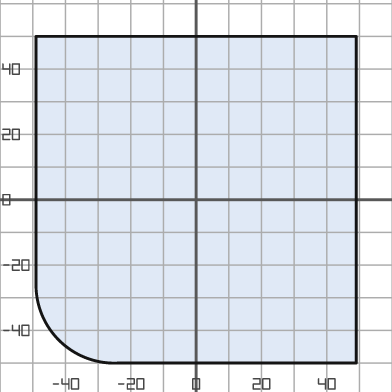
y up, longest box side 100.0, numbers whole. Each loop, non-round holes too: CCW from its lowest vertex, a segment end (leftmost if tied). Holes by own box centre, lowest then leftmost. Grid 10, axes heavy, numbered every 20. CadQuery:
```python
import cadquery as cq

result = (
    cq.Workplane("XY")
    .moveTo(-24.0, -50.0)
    .lineTo(49.0, -50.0)
    .lineTo(49.0, 50.0)
    .lineTo(-49.0, 50.0)
    .lineTo(-49.0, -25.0)
    .threePointArc((-42.0, -43.0), (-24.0, -50.0))
    .close()
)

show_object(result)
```